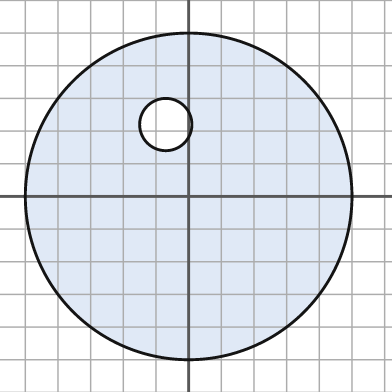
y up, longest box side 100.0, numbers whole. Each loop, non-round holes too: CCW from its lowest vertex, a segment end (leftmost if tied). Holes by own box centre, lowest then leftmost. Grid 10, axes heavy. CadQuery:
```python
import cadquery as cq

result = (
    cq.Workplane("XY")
    .moveTo(0.0, 0.0)
    .circle(50.0)
    .moveTo(-7.0, 22.0)
    .circle(8.0)
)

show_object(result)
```